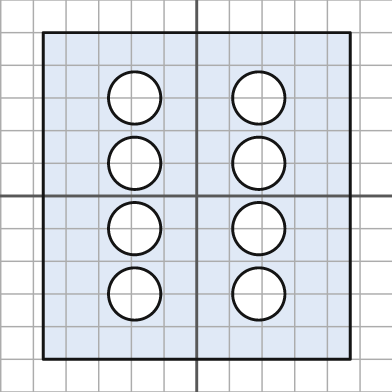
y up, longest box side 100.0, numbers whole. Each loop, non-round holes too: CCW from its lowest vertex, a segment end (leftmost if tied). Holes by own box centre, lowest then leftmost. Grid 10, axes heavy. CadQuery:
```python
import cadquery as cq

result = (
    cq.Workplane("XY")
    .moveTo(-47.0, -50.0)
    .lineTo(47.0, -50.0)
    .lineTo(47.0, 50.0)
    .lineTo(-47.0, 50.0)
    .close()
    .moveTo(-19.0, -30.0)
    .circle(8.0)
    .moveTo(19.0, -30.0)
    .circle(8.0)
    .moveTo(-19.0, -10.0)
    .circle(8.0)
    .moveTo(19.0, -10.0)
    .circle(8.0)
    .moveTo(-19.0, 10.0)
    .circle(8.0)
    .moveTo(19.0, 10.0)
    .circle(8.0)
    .moveTo(-19.0, 30.0)
    .circle(8.0)
    .moveTo(19.0, 30.0)
    .circle(8.0)
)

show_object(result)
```